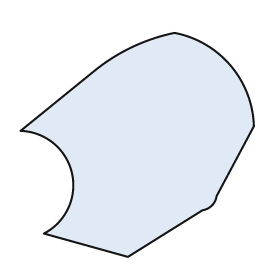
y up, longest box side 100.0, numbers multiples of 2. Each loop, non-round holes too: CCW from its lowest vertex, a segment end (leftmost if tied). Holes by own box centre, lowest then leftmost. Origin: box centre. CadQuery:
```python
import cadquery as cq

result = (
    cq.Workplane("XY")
    .moveTo(-4.0, -48.0)
    .lineTo(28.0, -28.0)
    .threePointArc((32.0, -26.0), (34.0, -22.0))
    .lineTo(50.0, 8.0)
    .threePointArc((40.0, 34.0), (16.0, 48.0))
    .threePointArc((-2.0, 42.0), (-18.0, 32.0))
    .lineTo(-50.0, 6.0)
    .threePointArc((-28.0, -12.0), (-40.0, -38.0))
    .close()
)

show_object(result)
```